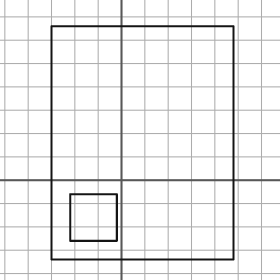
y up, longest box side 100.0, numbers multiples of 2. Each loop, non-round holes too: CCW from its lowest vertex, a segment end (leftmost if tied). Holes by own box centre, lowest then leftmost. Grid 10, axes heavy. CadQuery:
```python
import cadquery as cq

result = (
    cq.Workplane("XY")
    .moveTo(-30.0, -34.0)
    .lineTo(48.0, -34.0)
    .lineTo(48.0, 66.0)
    .lineTo(-30.0, 66.0)
    .close()
    .moveTo(-22.0, -26.0)
    .lineTo(-2.0, -26.0)
    .lineTo(-2.0, -6.0)
    .lineTo(-22.0, -6.0)
    .close()
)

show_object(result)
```